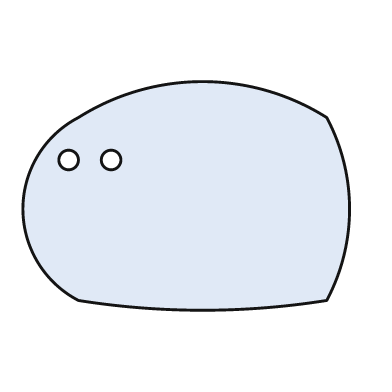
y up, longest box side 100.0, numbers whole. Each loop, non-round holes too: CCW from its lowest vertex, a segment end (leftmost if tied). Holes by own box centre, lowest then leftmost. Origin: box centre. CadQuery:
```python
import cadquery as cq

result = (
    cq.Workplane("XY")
    .moveTo(-33.0, -32.0)
    .threePointArc((5.0, -35.0), (43.0, -32.0))
    .threePointArc((50.0, -4.0), (43.0, 24.0))
    .threePointArc((5.0, 35.0), (-33.0, 24.0))
    .threePointArc((-50.0, -4.0), (-33.0, -32.0))
    .close()
    .moveTo(-36.0, 11.0)
    .circle(3.0)
    .moveTo(-23.0, 11.0)
    .circle(3.0)
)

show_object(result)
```